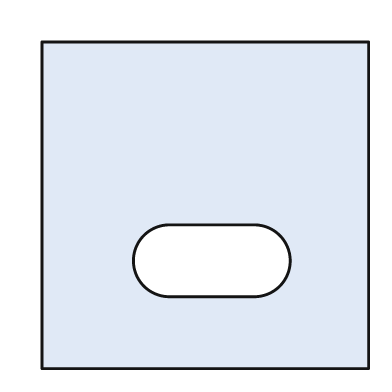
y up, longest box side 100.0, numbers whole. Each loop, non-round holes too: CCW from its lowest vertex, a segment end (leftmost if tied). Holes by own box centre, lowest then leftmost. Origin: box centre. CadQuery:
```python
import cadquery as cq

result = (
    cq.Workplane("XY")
    .moveTo(-50.0, -50.0)
    .lineTo(50.0, -50.0)
    .lineTo(50.0, 50.0)
    .lineTo(-50.0, 50.0)
    .close()
    .moveTo(-11.0, -28.0)
    .lineTo(15.0, -28.0)
    .threePointArc((26.0, -17.0), (15.0, -6.0))
    .lineTo(-11.0, -6.0)
    .threePointArc((-22.0, -17.0), (-11.0, -28.0))
    .close()
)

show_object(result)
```